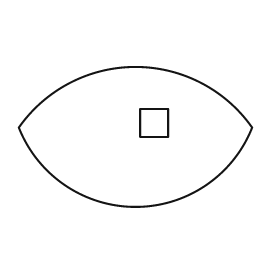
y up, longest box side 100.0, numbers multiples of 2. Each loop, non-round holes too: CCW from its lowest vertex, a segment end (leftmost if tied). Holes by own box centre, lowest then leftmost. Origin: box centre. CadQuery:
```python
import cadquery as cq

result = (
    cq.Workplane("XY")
    .moveTo(-50.0, 4.0)
    .threePointArc((0.0, -30.0), (50.0, 4.0))
    .threePointArc((0.0, 30.0), (-50.0, 4.0))
    .close()
    .moveTo(2.0, 0.0)
    .lineTo(14.0, 0.0)
    .lineTo(14.0, 12.0)
    .lineTo(2.0, 12.0)
    .close()
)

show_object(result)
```